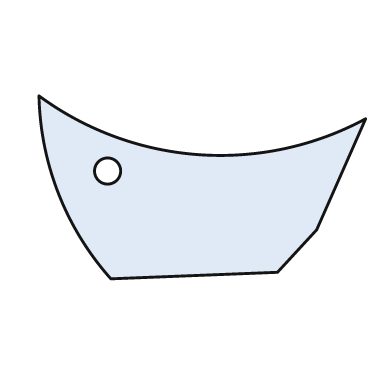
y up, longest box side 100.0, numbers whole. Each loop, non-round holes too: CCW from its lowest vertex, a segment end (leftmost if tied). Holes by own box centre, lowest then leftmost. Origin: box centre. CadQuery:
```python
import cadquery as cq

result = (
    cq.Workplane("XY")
    .moveTo(-28.0, -28.0)
    .lineTo(23.0, -26.0)
    .lineTo(35.0, -13.0)
    .lineTo(50.0, 21.0)
    .threePointArc((-1.0, 10.0), (-50.0, 28.0))
    .threePointArc((-44.0, -2.0), (-28.0, -28.0))
    .close()
    .moveTo(-29.0, 5.0)
    .circle(4.0)
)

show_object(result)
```